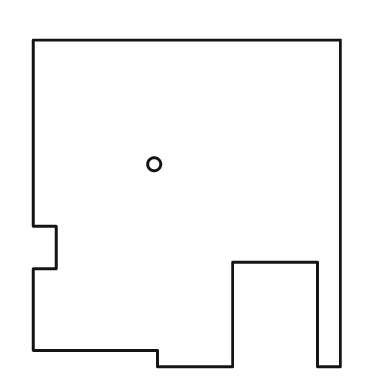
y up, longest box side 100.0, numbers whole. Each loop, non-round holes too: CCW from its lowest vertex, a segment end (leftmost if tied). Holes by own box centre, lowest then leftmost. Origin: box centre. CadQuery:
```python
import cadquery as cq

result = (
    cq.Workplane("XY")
    .moveTo(-9.0, -50.0)
    .lineTo(14.0, -50.0)
    .lineTo(14.0, -18.0)
    .lineTo(40.0, -18.0)
    .lineTo(40.0, -50.0)
    .lineTo(47.0, -50.0)
    .lineTo(47.0, 50.0)
    .lineTo(-47.0, 50.0)
    .lineTo(-47.0, -7.0)
    .lineTo(-40.0, -7.0)
    .lineTo(-40.0, -20.0)
    .lineTo(-47.0, -20.0)
    .lineTo(-47.0, -45.0)
    .lineTo(-9.0, -45.0)
    .close()
    .moveTo(-10.0, 12.0)
    .circle(2.0)
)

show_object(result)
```